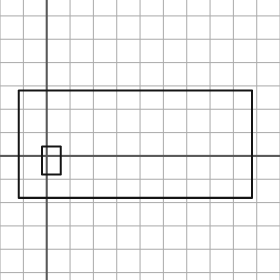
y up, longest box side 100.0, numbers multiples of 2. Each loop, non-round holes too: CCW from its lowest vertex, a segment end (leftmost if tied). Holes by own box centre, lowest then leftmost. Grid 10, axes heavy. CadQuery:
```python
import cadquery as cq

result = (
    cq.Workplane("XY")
    .moveTo(-12.0, -18.0)
    .lineTo(88.0, -18.0)
    .lineTo(88.0, 28.0)
    .lineTo(-12.0, 28.0)
    .close()
    .moveTo(-2.0, -8.0)
    .lineTo(6.0, -8.0)
    .lineTo(6.0, 4.0)
    .lineTo(-2.0, 4.0)
    .close()
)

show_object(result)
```